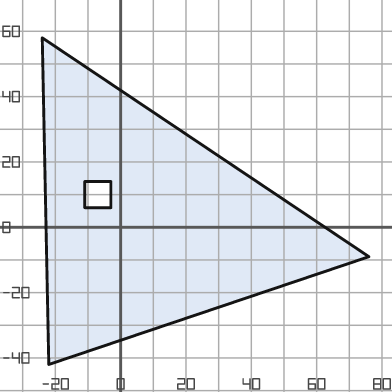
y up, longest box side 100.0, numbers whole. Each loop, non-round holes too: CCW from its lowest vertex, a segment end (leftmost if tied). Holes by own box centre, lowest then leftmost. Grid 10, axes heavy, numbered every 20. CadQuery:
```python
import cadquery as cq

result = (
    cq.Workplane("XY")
    .moveTo(-22.0, -42.0)
    .lineTo(76.0, -9.0)
    .lineTo(-24.0, 58.0)
    .close()
    .moveTo(-11.0, 6.0)
    .lineTo(-3.0, 6.0)
    .lineTo(-3.0, 14.0)
    .lineTo(-11.0, 14.0)
    .close()
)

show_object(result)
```